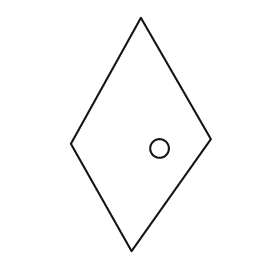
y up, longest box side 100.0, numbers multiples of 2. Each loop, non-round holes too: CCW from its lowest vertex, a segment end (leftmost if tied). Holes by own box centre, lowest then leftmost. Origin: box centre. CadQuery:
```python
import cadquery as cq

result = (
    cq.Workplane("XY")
    .moveTo(-4.0, -50.0)
    .lineTo(30.0, -2.0)
    .lineTo(0.0, 50.0)
    .lineTo(-30.0, -4.0)
    .close()
    .moveTo(8.0, -6.0)
    .circle(4.0)
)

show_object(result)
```